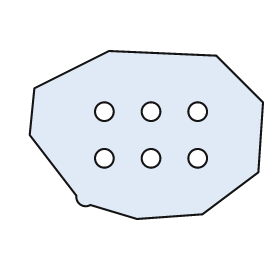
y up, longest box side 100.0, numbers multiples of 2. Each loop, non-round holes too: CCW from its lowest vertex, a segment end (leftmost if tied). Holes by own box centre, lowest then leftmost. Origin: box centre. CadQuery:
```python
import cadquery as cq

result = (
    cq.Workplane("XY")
    .moveTo(-4.0, -36.0)
    .lineTo(24.0, -34.0)
    .lineTo(48.0, -16.0)
    .lineTo(50.0, 14.0)
    .lineTo(30.0, 34.0)
    .lineTo(-16.0, 36.0)
    .lineTo(-48.0, 20.0)
    .lineTo(-50.0, 0.0)
    .lineTo(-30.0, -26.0)
    .threePointArc((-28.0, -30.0), (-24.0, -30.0))
    .close()
    .moveTo(-18.0, -10.0)
    .circle(4.0)
    .moveTo(2.0, -10.0)
    .circle(4.0)
    .moveTo(22.0, -10.0)
    .circle(4.0)
    .moveTo(-18.0, 10.0)
    .circle(4.0)
    .moveTo(2.0, 10.0)
    .circle(4.0)
    .moveTo(22.0, 10.0)
    .circle(4.0)
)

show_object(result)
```